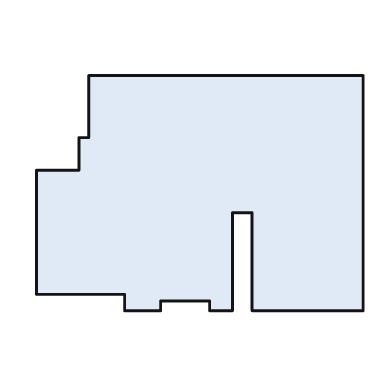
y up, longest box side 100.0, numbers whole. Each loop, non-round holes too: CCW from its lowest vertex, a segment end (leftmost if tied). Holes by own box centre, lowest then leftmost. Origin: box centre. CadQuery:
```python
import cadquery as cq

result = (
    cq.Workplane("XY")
    .moveTo(-23.0, -36.0)
    .lineTo(-12.0, -36.0)
    .lineTo(-12.0, -33.0)
    .lineTo(3.0, -33.0)
    .lineTo(3.0, -36.0)
    .lineTo(10.0, -36.0)
    .lineTo(10.0, -6.0)
    .lineTo(16.0, -6.0)
    .lineTo(16.0, -36.0)
    .lineTo(50.0, -36.0)
    .lineTo(50.0, 36.0)
    .lineTo(-34.0, 36.0)
    .lineTo(-34.0, 17.0)
    .lineTo(-37.0, 17.0)
    .lineTo(-37.0, 7.0)
    .lineTo(-50.0, 7.0)
    .lineTo(-50.0, -31.0)
    .lineTo(-23.0, -31.0)
    .close()
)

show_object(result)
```